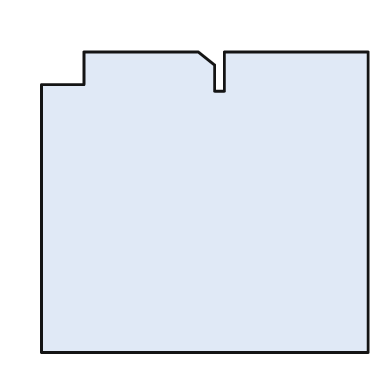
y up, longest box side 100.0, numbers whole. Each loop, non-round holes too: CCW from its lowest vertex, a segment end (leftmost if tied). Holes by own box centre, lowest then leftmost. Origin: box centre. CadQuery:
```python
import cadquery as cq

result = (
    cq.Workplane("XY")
    .moveTo(-50.0, -46.0)
    .lineTo(50.0, -46.0)
    .lineTo(50.0, 46.0)
    .lineTo(6.0, 46.0)
    .lineTo(6.0, 34.0)
    .lineTo(3.0, 34.0)
    .lineTo(3.0, 42.0)
    .lineTo(-2.0, 46.0)
    .lineTo(-37.0, 46.0)
    .lineTo(-37.0, 36.0)
    .lineTo(-50.0, 36.0)
    .close()
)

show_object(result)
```